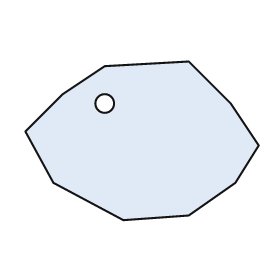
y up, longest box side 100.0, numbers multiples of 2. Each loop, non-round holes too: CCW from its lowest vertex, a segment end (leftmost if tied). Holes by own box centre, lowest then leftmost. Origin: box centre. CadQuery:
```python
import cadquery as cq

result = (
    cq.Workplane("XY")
    .moveTo(-8.0, -34.0)
    .lineTo(20.0, -32.0)
    .lineTo(40.0, -18.0)
    .lineTo(50.0, -2.0)
    .lineTo(38.0, 16.0)
    .lineTo(20.0, 34.0)
    .lineTo(-16.0, 32.0)
    .lineTo(-34.0, 20.0)
    .lineTo(-50.0, 4.0)
    .lineTo(-38.0, -18.0)
    .close()
    .moveTo(-16.0, 16.0)
    .circle(4.0)
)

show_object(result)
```